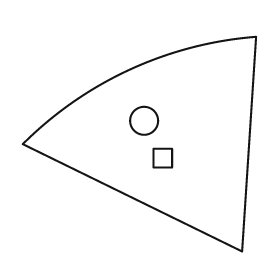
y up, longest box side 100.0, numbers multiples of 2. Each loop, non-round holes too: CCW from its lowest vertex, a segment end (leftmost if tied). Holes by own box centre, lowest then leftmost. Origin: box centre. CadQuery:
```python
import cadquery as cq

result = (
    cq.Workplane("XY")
    .moveTo(44.0, -46.0)
    .lineTo(50.0, 46.0)
    .threePointArc((-4.0, 32.0), (-50.0, 0.0))
    .close()
    .moveTo(6.0, -10.0)
    .lineTo(14.0, -10.0)
    .lineTo(14.0, -2.0)
    .lineTo(6.0, -2.0)
    .close()
    .moveTo(2.0, 10.0)
    .circle(6.0)
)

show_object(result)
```